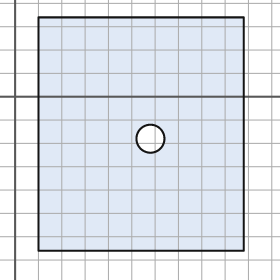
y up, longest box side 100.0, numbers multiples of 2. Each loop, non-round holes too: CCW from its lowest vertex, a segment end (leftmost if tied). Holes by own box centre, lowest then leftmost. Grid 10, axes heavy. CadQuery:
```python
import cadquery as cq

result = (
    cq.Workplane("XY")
    .moveTo(10.0, -66.0)
    .lineTo(98.0, -66.0)
    .lineTo(98.0, 34.0)
    .lineTo(10.0, 34.0)
    .close()
    .moveTo(58.0, -18.0)
    .circle(6.0)
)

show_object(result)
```